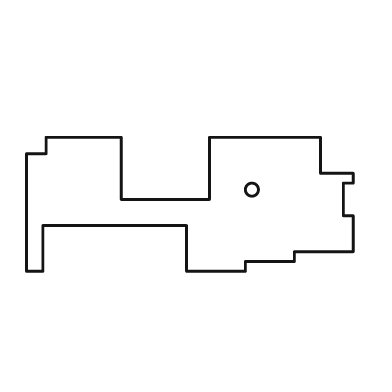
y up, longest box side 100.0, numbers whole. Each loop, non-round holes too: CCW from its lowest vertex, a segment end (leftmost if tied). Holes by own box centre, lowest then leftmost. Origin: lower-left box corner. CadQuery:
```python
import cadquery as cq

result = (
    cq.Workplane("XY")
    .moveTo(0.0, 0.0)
    .lineTo(5.0, 0.0)
    .lineTo(5.0, 14.0)
    .lineTo(49.0, 14.0)
    .lineTo(49.0, 0.0)
    .lineTo(67.0, 0.0)
    .lineTo(67.0, 3.0)
    .lineTo(82.0, 3.0)
    .lineTo(82.0, 6.0)
    .lineTo(100.0, 6.0)
    .lineTo(100.0, 17.0)
    .lineTo(97.0, 17.0)
    .lineTo(97.0, 27.0)
    .lineTo(100.0, 27.0)
    .lineTo(100.0, 30.0)
    .lineTo(90.0, 30.0)
    .lineTo(90.0, 41.0)
    .lineTo(56.0, 41.0)
    .lineTo(56.0, 22.0)
    .lineTo(29.0, 22.0)
    .lineTo(29.0, 41.0)
    .lineTo(6.0, 41.0)
    .lineTo(6.0, 36.0)
    .lineTo(0.0, 36.0)
    .close()
    .moveTo(69.0, 25.0)
    .circle(2.0)
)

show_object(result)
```